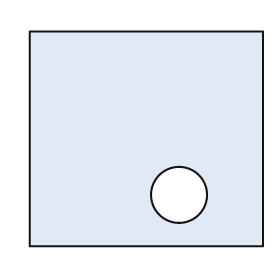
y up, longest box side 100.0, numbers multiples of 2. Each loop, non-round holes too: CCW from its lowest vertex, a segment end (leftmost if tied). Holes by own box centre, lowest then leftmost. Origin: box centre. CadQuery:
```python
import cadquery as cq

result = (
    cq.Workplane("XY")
    .moveTo(-50.0, -46.0)
    .lineTo(50.0, -46.0)
    .lineTo(50.0, 46.0)
    .lineTo(-50.0, 46.0)
    .close()
    .moveTo(14.0, -24.0)
    .circle(12.0)
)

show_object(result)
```